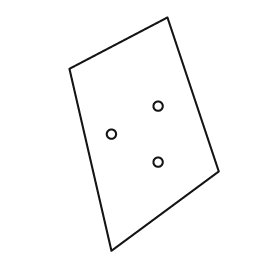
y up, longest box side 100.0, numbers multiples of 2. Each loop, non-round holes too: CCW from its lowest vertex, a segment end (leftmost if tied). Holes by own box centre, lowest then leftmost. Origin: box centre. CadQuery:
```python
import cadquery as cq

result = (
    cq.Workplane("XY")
    .moveTo(-14.0, -50.0)
    .lineTo(32.0, -16.0)
    .lineTo(10.0, 50.0)
    .lineTo(-32.0, 28.0)
    .close()
    .moveTo(6.0, -12.0)
    .circle(2.0)
    .moveTo(-14.0, 0.0)
    .circle(2.0)
    .moveTo(6.0, 12.0)
    .circle(2.0)
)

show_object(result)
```